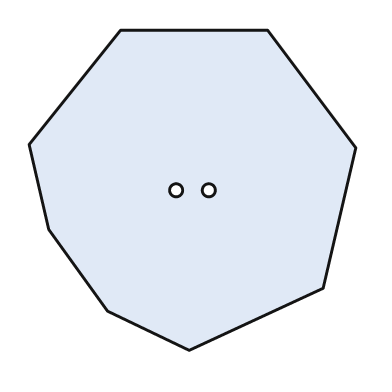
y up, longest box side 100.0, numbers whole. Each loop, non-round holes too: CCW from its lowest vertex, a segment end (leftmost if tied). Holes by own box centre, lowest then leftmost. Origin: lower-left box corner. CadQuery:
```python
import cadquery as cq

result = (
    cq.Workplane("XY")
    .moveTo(49.0, 0.0)
    .lineTo(90.0, 19.0)
    .lineTo(100.0, 62.0)
    .lineTo(73.0, 98.0)
    .lineTo(28.0, 98.0)
    .lineTo(0.0, 63.0)
    .lineTo(6.0, 37.0)
    .lineTo(24.0, 12.0)
    .close()
    .moveTo(45.0, 49.0)
    .circle(2.0)
    .moveTo(55.0, 49.0)
    .circle(2.0)
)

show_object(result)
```